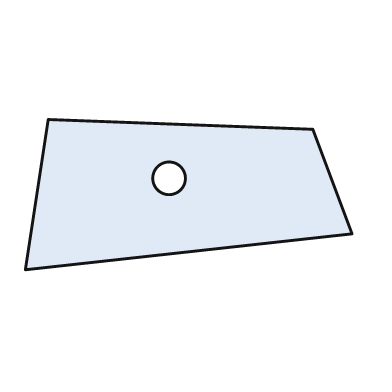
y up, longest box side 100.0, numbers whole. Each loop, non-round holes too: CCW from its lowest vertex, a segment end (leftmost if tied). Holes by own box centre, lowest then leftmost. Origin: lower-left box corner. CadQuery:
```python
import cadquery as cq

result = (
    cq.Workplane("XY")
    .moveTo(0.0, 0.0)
    .lineTo(100.0, 11.0)
    .lineTo(88.0, 43.0)
    .lineTo(7.0, 46.0)
    .close()
    .moveTo(44.0, 28.0)
    .circle(5.0)
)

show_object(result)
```